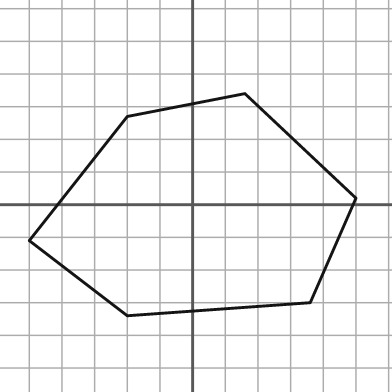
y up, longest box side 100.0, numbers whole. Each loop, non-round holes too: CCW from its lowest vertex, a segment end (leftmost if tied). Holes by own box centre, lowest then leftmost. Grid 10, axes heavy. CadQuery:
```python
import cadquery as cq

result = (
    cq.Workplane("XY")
    .moveTo(-20.0, -34.0)
    .lineTo(36.0, -30.0)
    .lineTo(50.0, 2.0)
    .lineTo(16.0, 34.0)
    .lineTo(-20.0, 27.0)
    .lineTo(-50.0, -11.0)
    .close()
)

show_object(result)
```